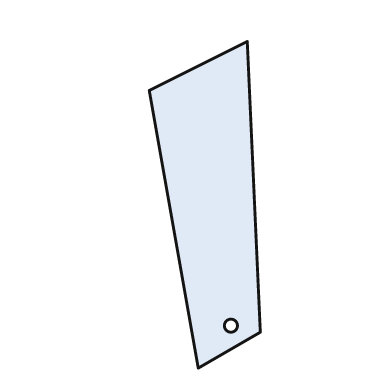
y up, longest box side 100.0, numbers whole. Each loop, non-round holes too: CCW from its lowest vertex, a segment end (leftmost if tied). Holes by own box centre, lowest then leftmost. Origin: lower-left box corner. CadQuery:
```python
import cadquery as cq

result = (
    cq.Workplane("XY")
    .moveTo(15.0, 0.0)
    .lineTo(34.0, 11.0)
    .lineTo(30.0, 100.0)
    .lineTo(0.0, 85.0)
    .close()
    .moveTo(25.0, 13.0)
    .circle(2.0)
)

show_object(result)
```